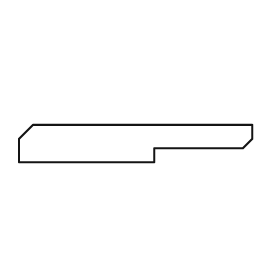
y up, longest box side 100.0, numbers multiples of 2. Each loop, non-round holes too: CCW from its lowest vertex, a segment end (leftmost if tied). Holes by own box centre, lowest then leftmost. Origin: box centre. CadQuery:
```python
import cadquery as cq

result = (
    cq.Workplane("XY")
    .moveTo(-50.0, -8.0)
    .lineTo(8.0, -8.0)
    .lineTo(8.0, -2.0)
    .lineTo(46.0, -2.0)
    .lineTo(50.0, 2.0)
    .lineTo(50.0, 8.0)
    .lineTo(-44.0, 8.0)
    .lineTo(-50.0, 2.0)
    .close()
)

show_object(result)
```